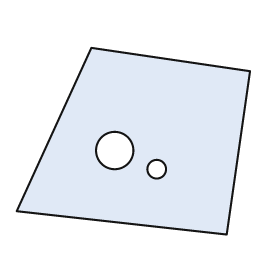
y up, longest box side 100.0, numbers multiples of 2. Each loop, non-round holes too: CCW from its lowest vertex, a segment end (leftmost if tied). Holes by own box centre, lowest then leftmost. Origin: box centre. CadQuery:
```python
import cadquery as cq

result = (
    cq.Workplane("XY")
    .moveTo(40.0, -40.0)
    .lineTo(50.0, 30.0)
    .lineTo(-18.0, 40.0)
    .lineTo(-50.0, -30.0)
    .close()
    .moveTo(10.0, -12.0)
    .circle(4.0)
    .moveTo(-8.0, -4.0)
    .circle(8.0)
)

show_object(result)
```